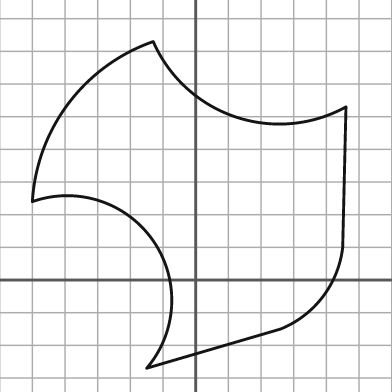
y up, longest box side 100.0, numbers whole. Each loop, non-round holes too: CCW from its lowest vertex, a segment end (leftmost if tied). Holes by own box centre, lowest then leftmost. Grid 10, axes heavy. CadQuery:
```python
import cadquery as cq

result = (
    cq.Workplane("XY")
    .moveTo(-15.0, -27.0)
    .lineTo(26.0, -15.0)
    .threePointArc((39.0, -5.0), (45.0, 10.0))
    .lineTo(46.0, 53.0)
    .threePointArc((12.0, 50.0), (-13.0, 73.0))
    .threePointArc((-39.0, 54.0), (-50.0, 24.0))
    .threePointArc((-13.0, 12.0), (-15.0, -27.0))
    .close()
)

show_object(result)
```